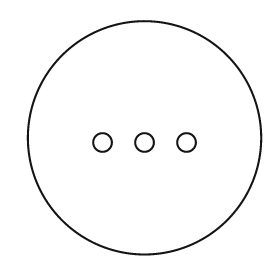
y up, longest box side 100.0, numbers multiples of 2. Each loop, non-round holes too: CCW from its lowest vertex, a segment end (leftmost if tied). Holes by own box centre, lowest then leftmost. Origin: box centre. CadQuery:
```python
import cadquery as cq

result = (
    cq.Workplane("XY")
    .moveTo(0.0, 0.0)
    .circle(50.0)
    .moveTo(-18.0, -2.0)
    .circle(4.0)
    .moveTo(0.0, -2.0)
    .circle(4.0)
    .moveTo(18.0, -2.0)
    .circle(4.0)
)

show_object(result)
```